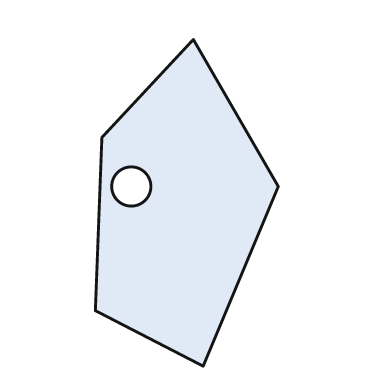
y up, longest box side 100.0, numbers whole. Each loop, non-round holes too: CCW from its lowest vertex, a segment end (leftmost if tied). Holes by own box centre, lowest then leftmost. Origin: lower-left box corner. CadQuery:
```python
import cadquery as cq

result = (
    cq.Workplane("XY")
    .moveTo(33.0, 0.0)
    .lineTo(56.0, 55.0)
    .lineTo(30.0, 100.0)
    .lineTo(2.0, 70.0)
    .lineTo(0.0, 17.0)
    .close()
    .moveTo(11.0, 55.0)
    .circle(6.0)
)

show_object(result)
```